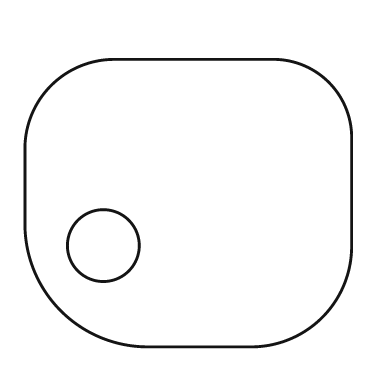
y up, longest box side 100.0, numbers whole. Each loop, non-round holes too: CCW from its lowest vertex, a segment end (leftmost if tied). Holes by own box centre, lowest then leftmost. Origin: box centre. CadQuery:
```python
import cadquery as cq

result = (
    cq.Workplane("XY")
    .moveTo(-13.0, -44.0)
    .lineTo(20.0, -44.0)
    .threePointArc((41.0, -35.0), (50.0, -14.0))
    .lineTo(50.0, 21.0)
    .threePointArc((43.0, 37.0), (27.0, 44.0))
    .lineTo(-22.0, 44.0)
    .threePointArc((-42.0, 36.0), (-50.0, 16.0))
    .lineTo(-50.0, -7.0)
    .threePointArc((-39.0, -33.0), (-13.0, -44.0))
    .close()
    .moveTo(-26.0, -13.0)
    .circle(11.0)
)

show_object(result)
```